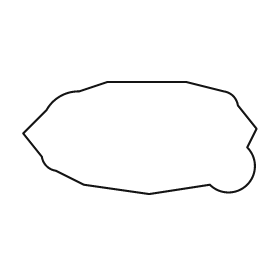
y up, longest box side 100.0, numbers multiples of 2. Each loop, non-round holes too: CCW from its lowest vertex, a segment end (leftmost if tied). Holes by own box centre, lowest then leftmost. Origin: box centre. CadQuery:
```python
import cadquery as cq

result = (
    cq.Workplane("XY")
    .moveTo(4.0, -24.0)
    .lineTo(30.0, -20.0)
    .threePointArc((46.0, -20.0), (46.0, -4.0))
    .lineTo(50.0, 4.0)
    .lineTo(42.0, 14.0)
    .threePointArc((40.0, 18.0), (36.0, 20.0))
    .lineTo(20.0, 24.0)
    .lineTo(-14.0, 24.0)
    .lineTo(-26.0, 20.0)
    .threePointArc((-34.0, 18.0), (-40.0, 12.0))
    .lineTo(-50.0, 2.0)
    .lineTo(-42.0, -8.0)
    .threePointArc((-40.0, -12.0), (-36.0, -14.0))
    .lineTo(-24.0, -20.0)
    .close()
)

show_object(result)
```